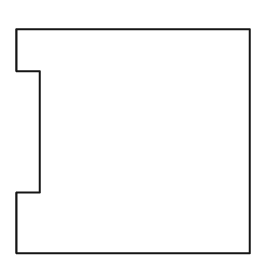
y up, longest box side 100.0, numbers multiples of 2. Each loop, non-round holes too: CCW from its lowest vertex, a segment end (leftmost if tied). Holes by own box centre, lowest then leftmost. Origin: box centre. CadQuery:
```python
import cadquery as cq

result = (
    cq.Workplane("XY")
    .moveTo(-50.0, -48.0)
    .lineTo(50.0, -48.0)
    .lineTo(50.0, 48.0)
    .lineTo(-50.0, 48.0)
    .lineTo(-50.0, 30.0)
    .lineTo(-40.0, 30.0)
    .lineTo(-40.0, -22.0)
    .lineTo(-50.0, -22.0)
    .close()
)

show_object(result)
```